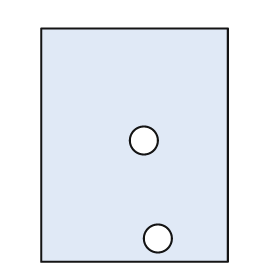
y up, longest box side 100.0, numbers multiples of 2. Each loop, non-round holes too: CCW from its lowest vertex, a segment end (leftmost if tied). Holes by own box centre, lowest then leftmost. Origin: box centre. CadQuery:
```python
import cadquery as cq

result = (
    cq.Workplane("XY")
    .moveTo(-40.0, -50.0)
    .lineTo(40.0, -50.0)
    .lineTo(40.0, 50.0)
    .lineTo(-40.0, 50.0)
    .close()
    .moveTo(10.0, -40.0)
    .circle(6.0)
    .moveTo(4.0, 2.0)
    .circle(6.0)
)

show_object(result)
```